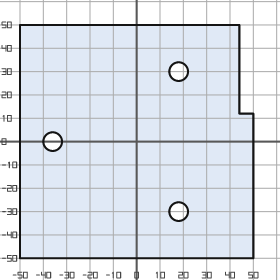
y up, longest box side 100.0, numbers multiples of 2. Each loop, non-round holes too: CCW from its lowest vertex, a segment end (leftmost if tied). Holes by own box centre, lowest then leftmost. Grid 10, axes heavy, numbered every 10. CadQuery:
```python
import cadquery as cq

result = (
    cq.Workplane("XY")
    .moveTo(-50.0, -50.0)
    .lineTo(50.0, -50.0)
    .lineTo(50.0, 12.0)
    .lineTo(44.0, 12.0)
    .lineTo(44.0, 50.0)
    .lineTo(-50.0, 50.0)
    .close()
    .moveTo(18.0, -30.0)
    .circle(4.0)
    .moveTo(-36.0, 0.0)
    .circle(4.0)
    .moveTo(18.0, 30.0)
    .circle(4.0)
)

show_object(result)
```